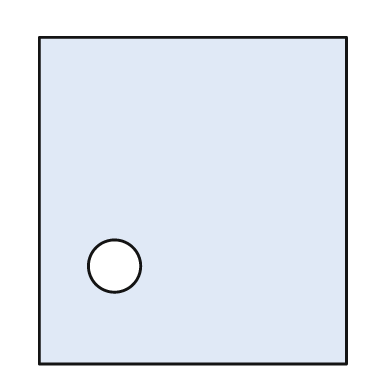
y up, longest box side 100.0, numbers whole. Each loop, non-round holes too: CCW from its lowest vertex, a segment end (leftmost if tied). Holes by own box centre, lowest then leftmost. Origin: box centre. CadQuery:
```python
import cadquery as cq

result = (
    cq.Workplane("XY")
    .moveTo(-47.0, -50.0)
    .lineTo(47.0, -50.0)
    .lineTo(47.0, 50.0)
    .lineTo(-47.0, 50.0)
    .close()
    .moveTo(-24.0, -20.0)
    .circle(8.0)
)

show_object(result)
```